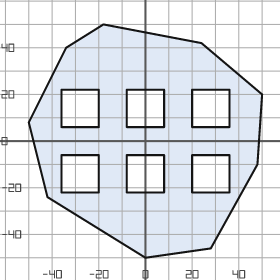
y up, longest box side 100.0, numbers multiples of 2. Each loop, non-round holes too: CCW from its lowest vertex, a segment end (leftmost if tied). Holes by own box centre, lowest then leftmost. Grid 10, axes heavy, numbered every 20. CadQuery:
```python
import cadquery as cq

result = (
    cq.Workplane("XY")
    .moveTo(0.0, -50.0)
    .lineTo(28.0, -46.0)
    .lineTo(48.0, -10.0)
    .lineTo(50.0, 20.0)
    .lineTo(24.0, 42.0)
    .lineTo(-18.0, 50.0)
    .lineTo(-34.0, 40.0)
    .lineTo(-50.0, 8.0)
    .lineTo(-42.0, -24.0)
    .close()
    .moveTo(-36.0, -22.0)
    .lineTo(-20.0, -22.0)
    .lineTo(-20.0, -6.0)
    .lineTo(-36.0, -6.0)
    .close()
    .moveTo(-8.0, -22.0)
    .lineTo(8.0, -22.0)
    .lineTo(8.0, -6.0)
    .lineTo(-8.0, -6.0)
    .close()
    .moveTo(20.0, -22.0)
    .lineTo(36.0, -22.0)
    .lineTo(36.0, -6.0)
    .lineTo(20.0, -6.0)
    .close()
    .moveTo(-36.0, 6.0)
    .lineTo(-20.0, 6.0)
    .lineTo(-20.0, 22.0)
    .lineTo(-36.0, 22.0)
    .close()
    .moveTo(-8.0, 6.0)
    .lineTo(8.0, 6.0)
    .lineTo(8.0, 22.0)
    .lineTo(-8.0, 22.0)
    .close()
    .moveTo(20.0, 6.0)
    .lineTo(36.0, 6.0)
    .lineTo(36.0, 22.0)
    .lineTo(20.0, 22.0)
    .close()
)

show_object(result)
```